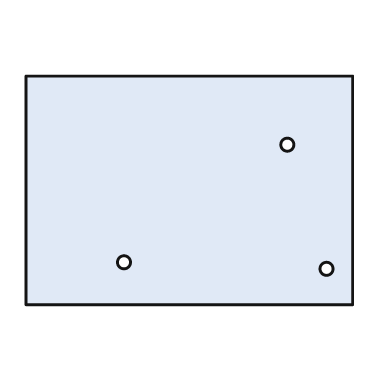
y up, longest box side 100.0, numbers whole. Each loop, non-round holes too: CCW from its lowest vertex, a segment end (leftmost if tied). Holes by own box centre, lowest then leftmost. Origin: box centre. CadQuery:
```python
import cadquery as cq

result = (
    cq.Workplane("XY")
    .moveTo(-50.0, -35.0)
    .lineTo(50.0, -35.0)
    .lineTo(50.0, 35.0)
    .lineTo(-50.0, 35.0)
    .close()
    .moveTo(42.0, -24.0)
    .circle(2.0)
    .moveTo(-20.0, -22.0)
    .circle(2.0)
    .moveTo(30.0, 14.0)
    .circle(2.0)
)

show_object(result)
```